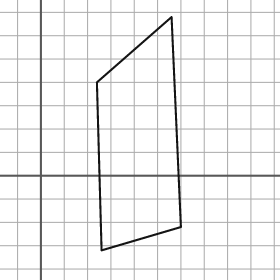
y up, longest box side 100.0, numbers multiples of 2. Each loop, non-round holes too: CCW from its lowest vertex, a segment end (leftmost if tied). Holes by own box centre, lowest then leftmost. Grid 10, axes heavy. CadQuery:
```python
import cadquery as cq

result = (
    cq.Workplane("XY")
    .moveTo(26.0, -32.0)
    .lineTo(60.0, -22.0)
    .lineTo(56.0, 68.0)
    .lineTo(24.0, 40.0)
    .close()
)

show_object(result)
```